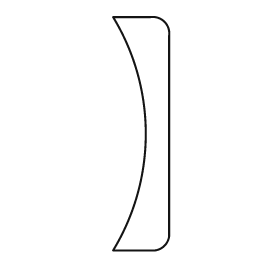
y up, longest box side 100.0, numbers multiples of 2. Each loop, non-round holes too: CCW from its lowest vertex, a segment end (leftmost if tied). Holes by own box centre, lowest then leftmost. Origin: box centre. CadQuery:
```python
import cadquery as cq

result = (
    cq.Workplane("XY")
    .moveTo(-12.0, -50.0)
    .lineTo(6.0, -50.0)
    .threePointArc((10.0, -48.0), (12.0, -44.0))
    .lineTo(12.0, 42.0)
    .threePointArc((10.0, 48.0), (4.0, 50.0))
    .lineTo(-12.0, 50.0)
    .threePointArc((2.0, 0.0), (-12.0, -50.0))
    .close()
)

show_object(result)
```